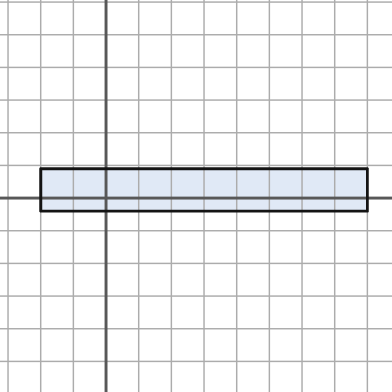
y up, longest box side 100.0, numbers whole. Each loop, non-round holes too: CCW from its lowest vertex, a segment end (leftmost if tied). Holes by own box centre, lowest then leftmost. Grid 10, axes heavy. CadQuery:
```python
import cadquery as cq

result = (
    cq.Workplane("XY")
    .moveTo(-20.0, -4.0)
    .lineTo(80.0, -4.0)
    .lineTo(80.0, 9.0)
    .lineTo(-20.0, 9.0)
    .close()
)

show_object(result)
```